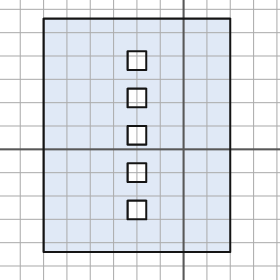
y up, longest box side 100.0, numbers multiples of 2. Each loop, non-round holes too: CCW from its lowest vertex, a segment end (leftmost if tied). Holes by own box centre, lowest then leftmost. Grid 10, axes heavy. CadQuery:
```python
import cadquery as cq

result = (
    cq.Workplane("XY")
    .moveTo(-60.0, -44.0)
    .lineTo(20.0, -44.0)
    .lineTo(20.0, 56.0)
    .lineTo(-60.0, 56.0)
    .close()
    .moveTo(-24.0, -30.0)
    .lineTo(-16.0, -30.0)
    .lineTo(-16.0, -22.0)
    .lineTo(-24.0, -22.0)
    .close()
    .moveTo(-24.0, -14.0)
    .lineTo(-16.0, -14.0)
    .lineTo(-16.0, -6.0)
    .lineTo(-24.0, -6.0)
    .close()
    .moveTo(-24.0, 2.0)
    .lineTo(-16.0, 2.0)
    .lineTo(-16.0, 10.0)
    .lineTo(-24.0, 10.0)
    .close()
    .moveTo(-24.0, 18.0)
    .lineTo(-16.0, 18.0)
    .lineTo(-16.0, 26.0)
    .lineTo(-24.0, 26.0)
    .close()
    .moveTo(-24.0, 34.0)
    .lineTo(-16.0, 34.0)
    .lineTo(-16.0, 42.0)
    .lineTo(-24.0, 42.0)
    .close()
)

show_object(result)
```